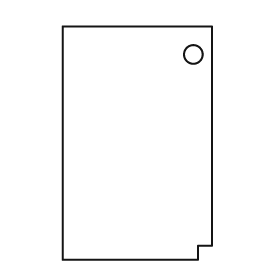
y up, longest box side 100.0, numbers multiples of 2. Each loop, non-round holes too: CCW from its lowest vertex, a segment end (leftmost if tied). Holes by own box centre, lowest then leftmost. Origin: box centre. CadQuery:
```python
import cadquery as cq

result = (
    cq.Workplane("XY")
    .moveTo(-32.0, -50.0)
    .lineTo(26.0, -50.0)
    .lineTo(26.0, -44.0)
    .lineTo(32.0, -44.0)
    .lineTo(32.0, 50.0)
    .lineTo(-32.0, 50.0)
    .close()
    .moveTo(24.0, 38.0)
    .circle(4.0)
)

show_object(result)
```